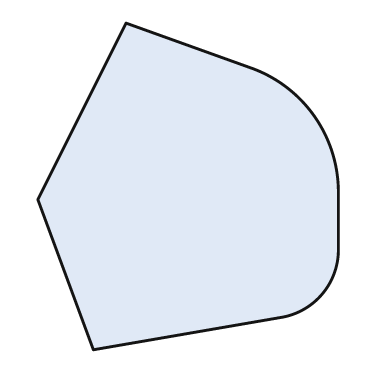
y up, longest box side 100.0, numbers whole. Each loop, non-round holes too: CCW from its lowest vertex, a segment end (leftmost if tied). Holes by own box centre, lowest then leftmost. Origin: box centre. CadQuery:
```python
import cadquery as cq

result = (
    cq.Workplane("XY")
    .moveTo(-29.0, -50.0)
    .lineTo(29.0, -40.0)
    .threePointArc((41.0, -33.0), (46.0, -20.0))
    .lineTo(46.0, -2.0)
    .threePointArc((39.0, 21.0), (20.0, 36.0))
    .lineTo(-19.0, 50.0)
    .lineTo(-46.0, -4.0)
    .close()
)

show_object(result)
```